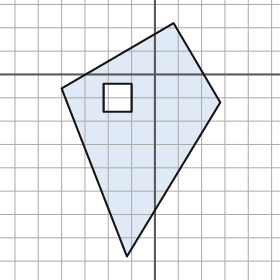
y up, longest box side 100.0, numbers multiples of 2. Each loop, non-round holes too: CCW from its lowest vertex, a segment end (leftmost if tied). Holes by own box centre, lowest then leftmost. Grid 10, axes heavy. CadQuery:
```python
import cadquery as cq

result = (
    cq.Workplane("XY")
    .moveTo(-12.0, -78.0)
    .lineTo(28.0, -12.0)
    .lineTo(8.0, 22.0)
    .lineTo(-40.0, -6.0)
    .close()
    .moveTo(-22.0, -16.0)
    .lineTo(-10.0, -16.0)
    .lineTo(-10.0, -4.0)
    .lineTo(-22.0, -4.0)
    .close()
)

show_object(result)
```